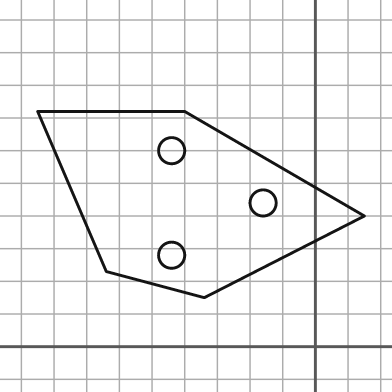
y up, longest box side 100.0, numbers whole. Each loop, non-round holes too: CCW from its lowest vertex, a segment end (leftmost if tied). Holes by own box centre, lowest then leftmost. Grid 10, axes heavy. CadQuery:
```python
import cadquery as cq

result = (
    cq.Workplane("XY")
    .moveTo(-34.0, 15.0)
    .lineTo(15.0, 40.0)
    .lineTo(-40.0, 72.0)
    .lineTo(-85.0, 72.0)
    .lineTo(-64.0, 23.0)
    .close()
    .moveTo(-44.0, 28.0)
    .circle(4.0)
    .moveTo(-16.0, 44.0)
    .circle(4.0)
    .moveTo(-44.0, 60.0)
    .circle(4.0)
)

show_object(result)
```